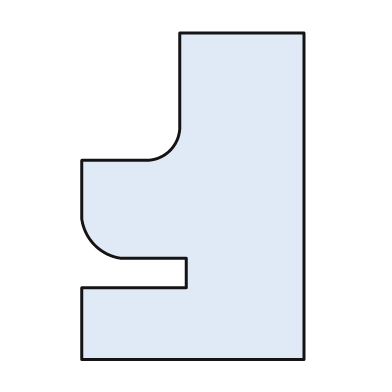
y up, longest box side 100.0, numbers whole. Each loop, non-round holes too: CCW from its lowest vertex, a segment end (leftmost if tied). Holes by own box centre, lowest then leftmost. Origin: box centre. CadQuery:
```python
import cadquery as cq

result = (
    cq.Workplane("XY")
    .moveTo(-34.0, -50.0)
    .lineTo(34.0, -50.0)
    .lineTo(34.0, 50.0)
    .lineTo(-4.0, 50.0)
    .lineTo(-4.0, 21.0)
    .threePointArc((-7.0, 14.0), (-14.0, 11.0))
    .lineTo(-34.0, 11.0)
    .lineTo(-34.0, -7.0)
    .threePointArc((-30.0, -15.0), (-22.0, -19.0))
    .lineTo(-2.0, -19.0)
    .lineTo(-2.0, -28.0)
    .lineTo(-34.0, -28.0)
    .close()
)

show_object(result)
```